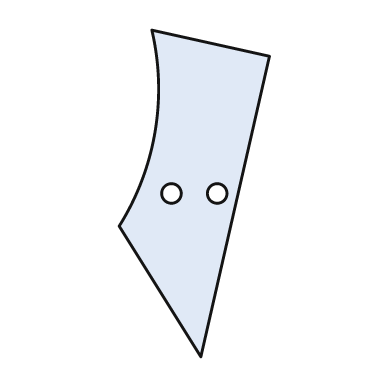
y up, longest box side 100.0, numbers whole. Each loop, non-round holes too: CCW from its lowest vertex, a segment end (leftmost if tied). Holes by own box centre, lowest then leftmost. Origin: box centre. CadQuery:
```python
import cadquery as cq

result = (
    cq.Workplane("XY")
    .moveTo(2.0, -50.0)
    .lineTo(23.0, 42.0)
    .lineTo(-13.0, 50.0)
    .threePointArc((-12.0, 19.0), (-23.0, -10.0))
    .close()
    .moveTo(-7.0, 0.0)
    .circle(3.0)
    .moveTo(7.0, 0.0)
    .circle(3.0)
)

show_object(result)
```